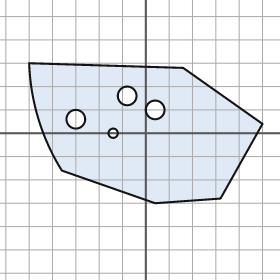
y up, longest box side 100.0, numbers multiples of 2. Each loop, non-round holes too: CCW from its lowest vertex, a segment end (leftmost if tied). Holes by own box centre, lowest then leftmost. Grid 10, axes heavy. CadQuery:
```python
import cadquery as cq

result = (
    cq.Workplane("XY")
    .moveTo(4.0, -30.0)
    .lineTo(32.0, -28.0)
    .lineTo(50.0, 4.0)
    .lineTo(16.0, 28.0)
    .lineTo(-50.0, 30.0)
    .threePointArc((-46.0, 6.0), (-36.0, -16.0))
    .close()
    .moveTo(-14.0, 0.0)
    .circle(2.0)
    .moveTo(-30.0, 6.0)
    .circle(4.0)
    .moveTo(4.0, 10.0)
    .circle(4.0)
    .moveTo(-8.0, 16.0)
    .circle(4.0)
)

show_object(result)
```